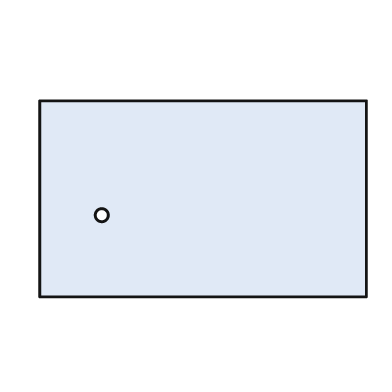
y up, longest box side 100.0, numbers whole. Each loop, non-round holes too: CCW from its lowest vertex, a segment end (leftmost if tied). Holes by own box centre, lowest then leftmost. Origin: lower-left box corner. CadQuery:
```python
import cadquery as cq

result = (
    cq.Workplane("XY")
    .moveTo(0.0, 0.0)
    .lineTo(100.0, 0.0)
    .lineTo(100.0, 60.0)
    .lineTo(0.0, 60.0)
    .close()
    .moveTo(19.0, 25.0)
    .circle(2.0)
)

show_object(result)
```